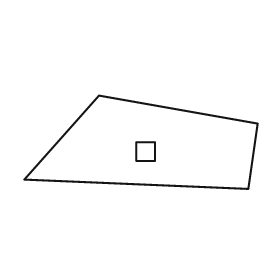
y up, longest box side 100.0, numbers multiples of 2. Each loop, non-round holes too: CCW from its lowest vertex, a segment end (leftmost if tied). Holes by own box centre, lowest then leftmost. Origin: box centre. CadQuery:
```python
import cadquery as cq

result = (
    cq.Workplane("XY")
    .moveTo(46.0, -20.0)
    .lineTo(50.0, 8.0)
    .lineTo(-18.0, 20.0)
    .lineTo(-50.0, -16.0)
    .close()
    .moveTo(-2.0, -8.0)
    .lineTo(6.0, -8.0)
    .lineTo(6.0, 0.0)
    .lineTo(-2.0, 0.0)
    .close()
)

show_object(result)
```